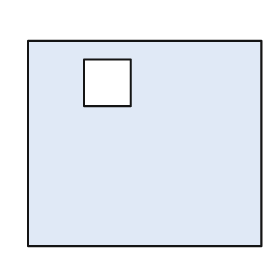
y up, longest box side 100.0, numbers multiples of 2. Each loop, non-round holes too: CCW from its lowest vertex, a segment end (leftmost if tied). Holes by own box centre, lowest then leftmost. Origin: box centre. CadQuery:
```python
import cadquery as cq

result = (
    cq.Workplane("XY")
    .moveTo(-50.0, -44.0)
    .lineTo(50.0, -44.0)
    .lineTo(50.0, 44.0)
    .lineTo(-50.0, 44.0)
    .close()
    .moveTo(-26.0, 16.0)
    .lineTo(-6.0, 16.0)
    .lineTo(-6.0, 36.0)
    .lineTo(-26.0, 36.0)
    .close()
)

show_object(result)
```